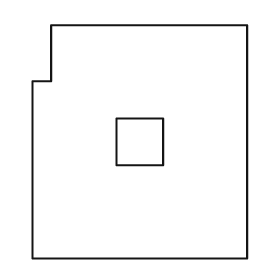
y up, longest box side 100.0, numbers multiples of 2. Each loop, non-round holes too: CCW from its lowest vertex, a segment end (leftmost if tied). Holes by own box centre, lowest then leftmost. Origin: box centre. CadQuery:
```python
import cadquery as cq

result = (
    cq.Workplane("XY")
    .moveTo(-46.0, -50.0)
    .lineTo(46.0, -50.0)
    .lineTo(46.0, 50.0)
    .lineTo(-38.0, 50.0)
    .lineTo(-38.0, 26.0)
    .lineTo(-46.0, 26.0)
    .close()
    .moveTo(-10.0, -10.0)
    .lineTo(10.0, -10.0)
    .lineTo(10.0, 10.0)
    .lineTo(-10.0, 10.0)
    .close()
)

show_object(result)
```